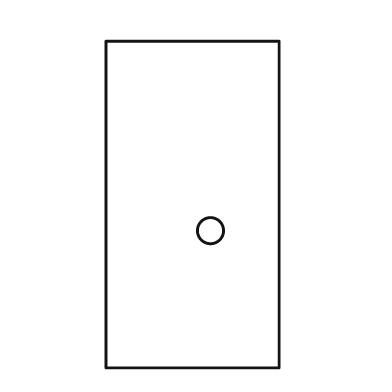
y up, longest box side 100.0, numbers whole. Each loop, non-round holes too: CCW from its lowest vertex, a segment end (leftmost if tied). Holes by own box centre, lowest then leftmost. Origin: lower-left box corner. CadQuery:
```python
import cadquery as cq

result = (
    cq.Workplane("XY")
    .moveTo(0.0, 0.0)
    .lineTo(53.0, 0.0)
    .lineTo(53.0, 100.0)
    .lineTo(0.0, 100.0)
    .close()
    .moveTo(32.0, 42.0)
    .circle(4.0)
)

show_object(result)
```